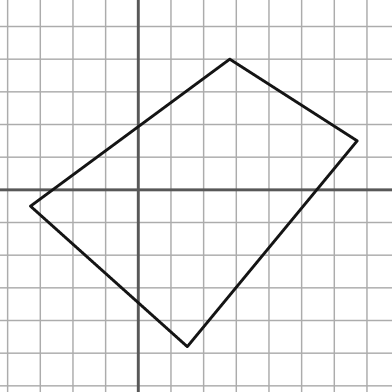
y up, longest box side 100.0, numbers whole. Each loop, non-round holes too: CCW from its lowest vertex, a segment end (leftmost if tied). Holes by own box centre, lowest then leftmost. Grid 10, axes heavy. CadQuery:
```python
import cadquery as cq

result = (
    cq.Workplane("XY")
    .moveTo(15.0, -48.0)
    .lineTo(67.0, 15.0)
    .lineTo(28.0, 40.0)
    .lineTo(-33.0, -5.0)
    .close()
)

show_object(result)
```